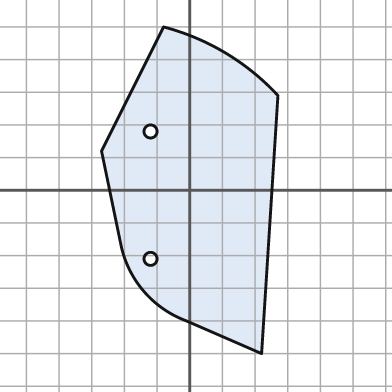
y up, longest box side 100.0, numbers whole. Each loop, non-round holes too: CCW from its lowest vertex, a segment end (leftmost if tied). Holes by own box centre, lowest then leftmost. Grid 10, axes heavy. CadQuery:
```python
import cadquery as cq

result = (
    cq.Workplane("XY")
    .moveTo(22.0, -50.0)
    .lineTo(27.0, 29.0)
    .threePointArc((11.0, 42.0), (-8.0, 50.0))
    .lineTo(-27.0, 12.0)
    .lineTo(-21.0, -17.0)
    .threePointArc((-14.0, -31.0), (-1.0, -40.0))
    .close()
    .moveTo(-12.0, -21.0)
    .circle(2.0)
    .moveTo(-12.0, 18.0)
    .circle(2.0)
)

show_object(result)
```